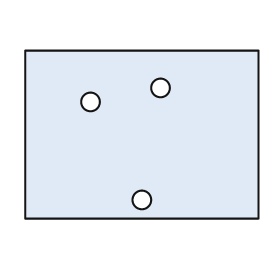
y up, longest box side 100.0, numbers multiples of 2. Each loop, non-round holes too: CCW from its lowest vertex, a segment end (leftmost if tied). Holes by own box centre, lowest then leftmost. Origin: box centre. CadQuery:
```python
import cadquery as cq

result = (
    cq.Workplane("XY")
    .moveTo(-50.0, -36.0)
    .lineTo(50.0, -36.0)
    .lineTo(50.0, 36.0)
    .lineTo(-50.0, 36.0)
    .close()
    .moveTo(0.0, -28.0)
    .circle(4.0)
    .moveTo(-22.0, 14.0)
    .circle(4.0)
    .moveTo(8.0, 20.0)
    .circle(4.0)
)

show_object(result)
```